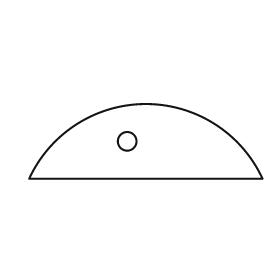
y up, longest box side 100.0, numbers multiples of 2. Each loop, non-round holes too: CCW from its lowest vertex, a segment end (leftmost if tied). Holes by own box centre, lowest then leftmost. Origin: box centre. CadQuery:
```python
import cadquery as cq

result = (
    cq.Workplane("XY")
    .moveTo(-50.0, -16.0)
    .lineTo(50.0, -16.0)
    .threePointArc((0.0, 16.0), (-50.0, -16.0))
    .close()
    .moveTo(-8.0, 0.0)
    .circle(4.0)
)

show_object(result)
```